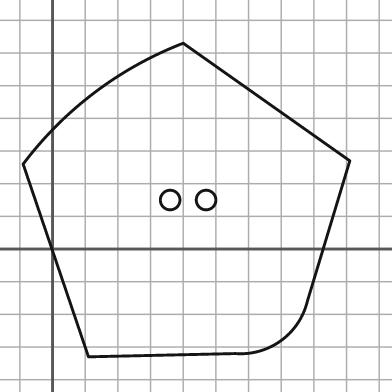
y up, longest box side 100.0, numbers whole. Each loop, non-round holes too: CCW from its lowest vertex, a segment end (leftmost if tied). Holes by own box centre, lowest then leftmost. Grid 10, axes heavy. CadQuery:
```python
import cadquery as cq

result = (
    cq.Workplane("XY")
    .moveTo(11.0, -33.0)
    .lineTo(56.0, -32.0)
    .threePointArc((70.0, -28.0), (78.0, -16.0))
    .lineTo(91.0, 27.0)
    .lineTo(40.0, 63.0)
    .threePointArc((13.0, 48.0), (-9.0, 26.0))
    .close()
    .moveTo(36.0, 15.0)
    .circle(3.0)
    .moveTo(47.0, 15.0)
    .circle(3.0)
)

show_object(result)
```